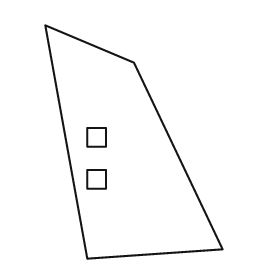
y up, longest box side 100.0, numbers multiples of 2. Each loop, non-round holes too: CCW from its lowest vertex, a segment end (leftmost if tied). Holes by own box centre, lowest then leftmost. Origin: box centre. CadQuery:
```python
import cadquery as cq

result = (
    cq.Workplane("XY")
    .moveTo(-20.0, -50.0)
    .lineTo(38.0, -46.0)
    .lineTo(0.0, 34.0)
    .lineTo(-38.0, 50.0)
    .close()
    .moveTo(-20.0, -20.0)
    .lineTo(-12.0, -20.0)
    .lineTo(-12.0, -12.0)
    .lineTo(-20.0, -12.0)
    .close()
    .moveTo(-20.0, -2.0)
    .lineTo(-12.0, -2.0)
    .lineTo(-12.0, 6.0)
    .lineTo(-20.0, 6.0)
    .close()
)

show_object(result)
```